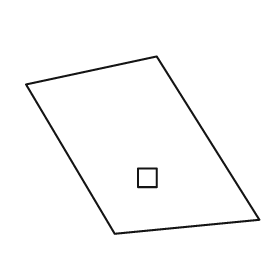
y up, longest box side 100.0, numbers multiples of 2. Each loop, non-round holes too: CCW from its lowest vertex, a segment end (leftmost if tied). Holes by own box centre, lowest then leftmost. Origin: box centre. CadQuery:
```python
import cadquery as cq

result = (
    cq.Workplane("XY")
    .moveTo(-12.0, -38.0)
    .lineTo(50.0, -32.0)
    .lineTo(6.0, 38.0)
    .lineTo(-50.0, 26.0)
    .close()
    .moveTo(-2.0, -18.0)
    .lineTo(6.0, -18.0)
    .lineTo(6.0, -10.0)
    .lineTo(-2.0, -10.0)
    .close()
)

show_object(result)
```